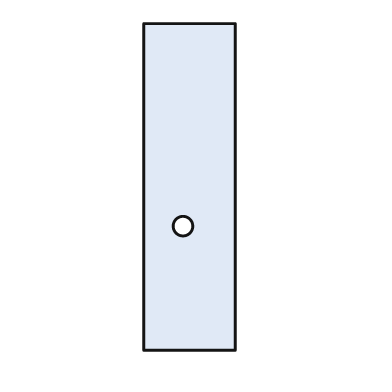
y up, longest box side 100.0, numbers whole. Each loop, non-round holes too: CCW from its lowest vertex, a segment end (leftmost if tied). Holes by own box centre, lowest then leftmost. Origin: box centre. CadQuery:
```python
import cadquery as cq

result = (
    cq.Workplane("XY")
    .moveTo(-14.0, -50.0)
    .lineTo(14.0, -50.0)
    .lineTo(14.0, 50.0)
    .lineTo(-14.0, 50.0)
    .close()
    .moveTo(-2.0, -12.0)
    .circle(3.0)
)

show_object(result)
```